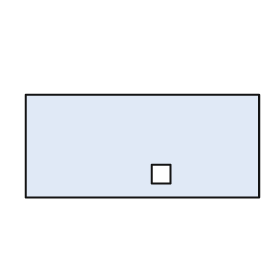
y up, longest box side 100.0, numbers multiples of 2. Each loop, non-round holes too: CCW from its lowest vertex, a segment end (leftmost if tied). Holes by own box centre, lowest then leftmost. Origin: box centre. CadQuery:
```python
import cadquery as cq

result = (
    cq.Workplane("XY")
    .moveTo(-50.0, -22.0)
    .lineTo(50.0, -22.0)
    .lineTo(50.0, 22.0)
    .lineTo(-50.0, 22.0)
    .close()
    .moveTo(4.0, -16.0)
    .lineTo(12.0, -16.0)
    .lineTo(12.0, -8.0)
    .lineTo(4.0, -8.0)
    .close()
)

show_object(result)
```